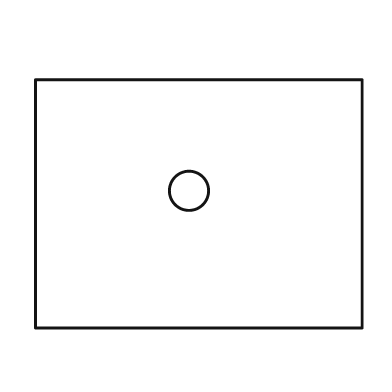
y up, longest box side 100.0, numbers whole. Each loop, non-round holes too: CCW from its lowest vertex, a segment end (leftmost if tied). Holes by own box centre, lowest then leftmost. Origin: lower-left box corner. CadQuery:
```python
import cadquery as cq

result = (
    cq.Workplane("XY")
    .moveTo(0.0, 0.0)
    .lineTo(100.0, 0.0)
    .lineTo(100.0, 76.0)
    .lineTo(0.0, 76.0)
    .close()
    .moveTo(47.0, 42.0)
    .circle(6.0)
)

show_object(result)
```